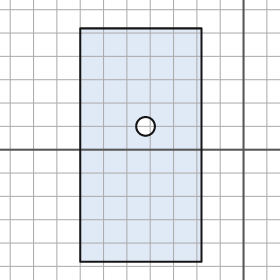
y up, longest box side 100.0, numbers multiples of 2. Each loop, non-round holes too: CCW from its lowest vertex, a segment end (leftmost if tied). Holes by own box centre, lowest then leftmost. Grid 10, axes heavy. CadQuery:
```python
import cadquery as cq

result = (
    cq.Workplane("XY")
    .moveTo(-70.0, -48.0)
    .lineTo(-18.0, -48.0)
    .lineTo(-18.0, 52.0)
    .lineTo(-70.0, 52.0)
    .close()
    .moveTo(-42.0, 10.0)
    .circle(4.0)
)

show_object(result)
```